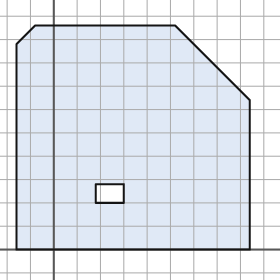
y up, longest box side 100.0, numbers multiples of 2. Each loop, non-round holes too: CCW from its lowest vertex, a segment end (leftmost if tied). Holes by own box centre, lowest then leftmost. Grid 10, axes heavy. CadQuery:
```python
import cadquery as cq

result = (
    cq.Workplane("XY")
    .moveTo(-16.0, 0.0)
    .lineTo(84.0, 0.0)
    .lineTo(84.0, 64.0)
    .lineTo(52.0, 96.0)
    .lineTo(-8.0, 96.0)
    .lineTo(-16.0, 88.0)
    .close()
    .moveTo(18.0, 20.0)
    .lineTo(30.0, 20.0)
    .lineTo(30.0, 28.0)
    .lineTo(18.0, 28.0)
    .close()
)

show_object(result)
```